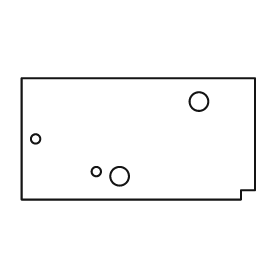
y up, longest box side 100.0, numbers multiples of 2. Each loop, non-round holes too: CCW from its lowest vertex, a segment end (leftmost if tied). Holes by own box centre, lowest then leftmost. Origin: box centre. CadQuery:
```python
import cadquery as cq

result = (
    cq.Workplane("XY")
    .moveTo(-50.0, -26.0)
    .lineTo(44.0, -26.0)
    .lineTo(44.0, -22.0)
    .lineTo(50.0, -22.0)
    .lineTo(50.0, 26.0)
    .lineTo(-50.0, 26.0)
    .close()
    .moveTo(-8.0, -16.0)
    .circle(4.0)
    .moveTo(-18.0, -14.0)
    .circle(2.0)
    .moveTo(-44.0, 0.0)
    .circle(2.0)
    .moveTo(26.0, 16.0)
    .circle(4.0)
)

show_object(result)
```